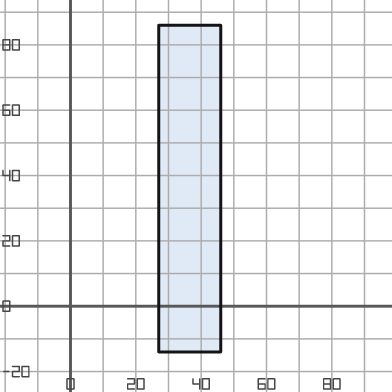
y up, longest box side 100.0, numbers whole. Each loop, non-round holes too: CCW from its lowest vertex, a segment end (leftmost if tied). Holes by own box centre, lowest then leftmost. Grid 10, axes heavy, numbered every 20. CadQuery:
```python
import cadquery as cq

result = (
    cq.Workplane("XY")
    .moveTo(27.0, -14.0)
    .lineTo(46.0, -14.0)
    .lineTo(46.0, 86.0)
    .lineTo(27.0, 86.0)
    .close()
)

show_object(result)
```